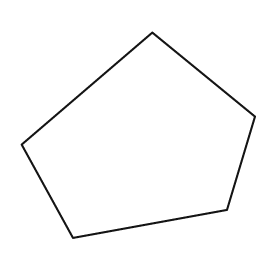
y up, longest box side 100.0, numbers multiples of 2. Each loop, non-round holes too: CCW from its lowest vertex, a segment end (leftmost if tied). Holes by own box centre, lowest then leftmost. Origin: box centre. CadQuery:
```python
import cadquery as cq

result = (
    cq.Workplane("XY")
    .moveTo(-28.0, -44.0)
    .lineTo(38.0, -32.0)
    .lineTo(50.0, 8.0)
    .lineTo(6.0, 44.0)
    .lineTo(-50.0, -4.0)
    .close()
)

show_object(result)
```